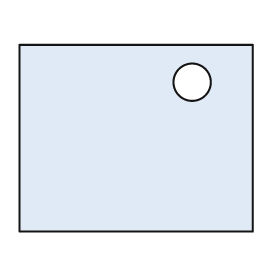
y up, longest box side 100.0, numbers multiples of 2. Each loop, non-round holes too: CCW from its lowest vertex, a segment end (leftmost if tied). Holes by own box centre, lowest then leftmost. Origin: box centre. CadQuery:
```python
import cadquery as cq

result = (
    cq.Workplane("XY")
    .moveTo(-50.0, -40.0)
    .lineTo(50.0, -40.0)
    .lineTo(50.0, 40.0)
    .lineTo(-50.0, 40.0)
    .close()
    .moveTo(24.0, 24.0)
    .circle(8.0)
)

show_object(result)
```